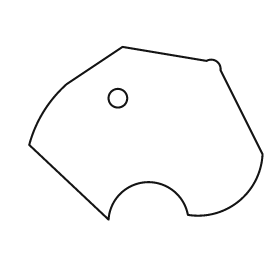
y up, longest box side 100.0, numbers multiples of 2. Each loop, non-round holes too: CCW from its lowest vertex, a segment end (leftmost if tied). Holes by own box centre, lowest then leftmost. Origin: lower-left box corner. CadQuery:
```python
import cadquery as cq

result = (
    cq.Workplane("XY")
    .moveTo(34.0, 0.0)
    .threePointArc((50.0, 16.0), (68.0, 2.0))
    .threePointArc((90.0, 8.0), (100.0, 28.0))
    .lineTo(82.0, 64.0)
    .threePointArc((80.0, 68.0), (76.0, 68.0))
    .lineTo(40.0, 74.0)
    .lineTo(16.0, 58.0)
    .threePointArc((6.0, 46.0), (0.0, 32.0))
    .close()
    .moveTo(38.0, 52.0)
    .circle(4.0)
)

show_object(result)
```